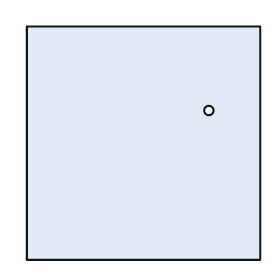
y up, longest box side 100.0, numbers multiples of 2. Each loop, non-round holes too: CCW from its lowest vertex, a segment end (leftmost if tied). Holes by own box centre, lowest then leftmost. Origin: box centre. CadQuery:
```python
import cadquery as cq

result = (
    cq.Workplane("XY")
    .moveTo(-50.0, -50.0)
    .lineTo(50.0, -50.0)
    .lineTo(50.0, 50.0)
    .lineTo(-50.0, 50.0)
    .close()
    .moveTo(28.0, 14.0)
    .circle(2.0)
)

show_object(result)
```